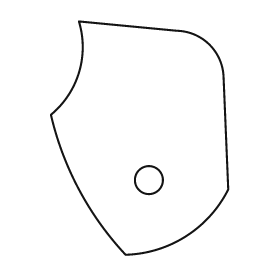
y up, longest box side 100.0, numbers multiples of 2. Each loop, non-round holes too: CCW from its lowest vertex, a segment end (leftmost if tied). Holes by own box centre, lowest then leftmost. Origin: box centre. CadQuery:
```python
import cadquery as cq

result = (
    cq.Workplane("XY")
    .moveTo(-6.0, -50.0)
    .threePointArc((20.0, -42.0), (38.0, -22.0))
    .lineTo(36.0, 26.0)
    .threePointArc((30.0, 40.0), (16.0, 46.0))
    .lineTo(-26.0, 50.0)
    .threePointArc((-26.0, 28.0), (-38.0, 10.0))
    .threePointArc((-26.0, -22.0), (-6.0, -50.0))
    .close()
    .moveTo(4.0, -18.0)
    .circle(6.0)
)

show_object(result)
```